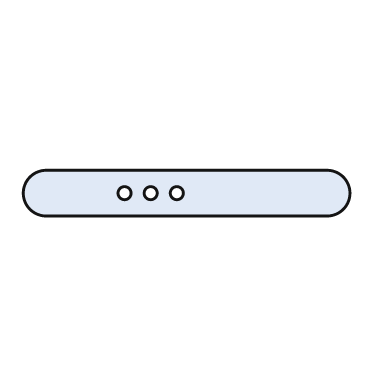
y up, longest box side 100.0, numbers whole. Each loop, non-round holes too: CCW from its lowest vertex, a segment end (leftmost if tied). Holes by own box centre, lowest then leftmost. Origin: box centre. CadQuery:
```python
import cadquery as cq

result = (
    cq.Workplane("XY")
    .moveTo(-43.0, -7.0)
    .lineTo(43.0, -7.0)
    .threePointArc((50.0, 0.0), (43.0, 7.0))
    .lineTo(-43.0, 7.0)
    .threePointArc((-50.0, 0.0), (-43.0, -7.0))
    .close()
    .moveTo(-19.0, 0.0)
    .circle(2.0)
    .moveTo(-11.0, 0.0)
    .circle(2.0)
    .moveTo(-3.0, 0.0)
    .circle(2.0)
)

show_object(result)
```